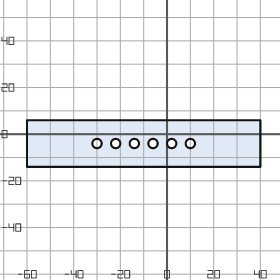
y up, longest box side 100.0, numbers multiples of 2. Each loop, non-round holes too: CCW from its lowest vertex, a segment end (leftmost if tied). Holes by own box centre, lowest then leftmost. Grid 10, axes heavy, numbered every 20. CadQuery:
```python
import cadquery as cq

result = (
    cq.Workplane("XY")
    .moveTo(-60.0, -14.0)
    .lineTo(40.0, -14.0)
    .lineTo(40.0, 6.0)
    .lineTo(-60.0, 6.0)
    .close()
    .moveTo(-30.0, -4.0)
    .circle(2.0)
    .moveTo(-22.0, -4.0)
    .circle(2.0)
    .moveTo(-14.0, -4.0)
    .circle(2.0)
    .moveTo(-6.0, -4.0)
    .circle(2.0)
    .moveTo(2.0, -4.0)
    .circle(2.0)
    .moveTo(10.0, -4.0)
    .circle(2.0)
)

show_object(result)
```